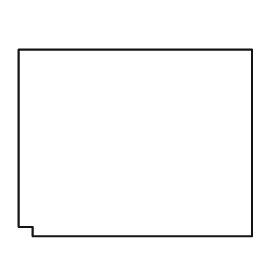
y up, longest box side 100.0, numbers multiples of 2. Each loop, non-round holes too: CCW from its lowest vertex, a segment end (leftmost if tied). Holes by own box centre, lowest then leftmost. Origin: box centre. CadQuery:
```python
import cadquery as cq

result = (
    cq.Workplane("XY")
    .moveTo(-44.0, -40.0)
    .lineTo(50.0, -40.0)
    .lineTo(50.0, 40.0)
    .lineTo(-50.0, 40.0)
    .lineTo(-50.0, -36.0)
    .lineTo(-44.0, -36.0)
    .close()
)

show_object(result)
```